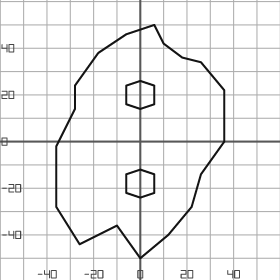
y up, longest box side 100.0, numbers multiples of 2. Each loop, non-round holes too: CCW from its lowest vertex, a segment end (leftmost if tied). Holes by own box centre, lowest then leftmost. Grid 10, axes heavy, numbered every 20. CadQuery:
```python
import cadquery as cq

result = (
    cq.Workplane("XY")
    .moveTo(0.0, -50.0)
    .lineTo(12.0, -40.0)
    .lineTo(22.0, -28.0)
    .lineTo(26.0, -14.0)
    .lineTo(36.0, 0.0)
    .lineTo(36.0, 22.0)
    .lineTo(26.0, 34.0)
    .lineTo(18.0, 36.0)
    .lineTo(10.0, 42.0)
    .lineTo(6.0, 50.0)
    .lineTo(-6.0, 46.0)
    .lineTo(-18.0, 38.0)
    .lineTo(-28.0, 24.0)
    .lineTo(-28.0, 14.0)
    .lineTo(-36.0, -2.0)
    .lineTo(-36.0, -28.0)
    .lineTo(-26.0, -44.0)
    .lineTo(-10.0, -36.0)
    .close()
    .moveTo(0.0, -24.0)
    .lineTo(6.0, -22.0)
    .lineTo(6.0, -14.0)
    .lineTo(0.0, -12.0)
    .lineTo(-6.0, -14.0)
    .lineTo(-6.0, -22.0)
    .close()
    .moveTo(0.0, 14.0)
    .lineTo(6.0, 16.0)
    .lineTo(6.0, 24.0)
    .lineTo(0.0, 26.0)
    .lineTo(-6.0, 24.0)
    .lineTo(-6.0, 16.0)
    .close()
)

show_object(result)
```